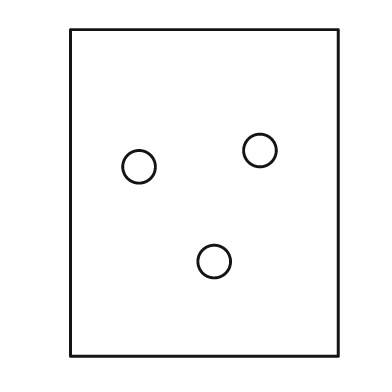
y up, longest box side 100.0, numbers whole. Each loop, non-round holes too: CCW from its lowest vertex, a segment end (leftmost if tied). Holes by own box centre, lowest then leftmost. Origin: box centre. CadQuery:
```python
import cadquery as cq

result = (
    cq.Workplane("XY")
    .moveTo(-41.0, -50.0)
    .lineTo(41.0, -50.0)
    .lineTo(41.0, 50.0)
    .lineTo(-41.0, 50.0)
    .close()
    .moveTo(3.0, -21.0)
    .circle(5.0)
    .moveTo(-20.0, 8.0)
    .circle(5.0)
    .moveTo(17.0, 13.0)
    .circle(5.0)
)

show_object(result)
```